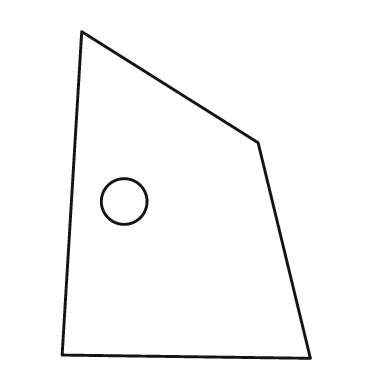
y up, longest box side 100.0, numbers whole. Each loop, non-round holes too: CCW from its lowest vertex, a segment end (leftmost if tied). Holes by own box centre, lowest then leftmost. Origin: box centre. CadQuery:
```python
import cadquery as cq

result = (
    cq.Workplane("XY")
    .moveTo(38.0, -50.0)
    .lineTo(22.0, 16.0)
    .lineTo(-32.0, 50.0)
    .lineTo(-38.0, -49.0)
    .close()
    .moveTo(-19.0, -2.0)
    .circle(7.0)
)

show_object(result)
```